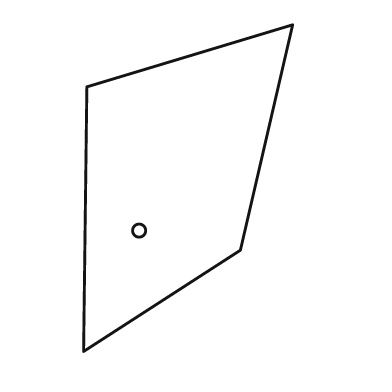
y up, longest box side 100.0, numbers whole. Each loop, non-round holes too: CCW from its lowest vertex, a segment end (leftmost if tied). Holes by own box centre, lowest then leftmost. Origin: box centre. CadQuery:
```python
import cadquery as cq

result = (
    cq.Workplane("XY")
    .moveTo(-32.0, -50.0)
    .lineTo(16.0, -19.0)
    .lineTo(32.0, 50.0)
    .lineTo(-31.0, 31.0)
    .close()
    .moveTo(-15.0, -13.0)
    .circle(2.0)
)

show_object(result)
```